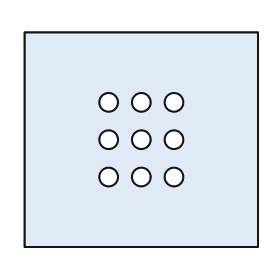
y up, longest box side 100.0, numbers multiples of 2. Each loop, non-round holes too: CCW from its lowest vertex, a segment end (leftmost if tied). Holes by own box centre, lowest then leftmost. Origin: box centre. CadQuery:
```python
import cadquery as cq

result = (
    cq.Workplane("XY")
    .moveTo(-50.0, -46.0)
    .lineTo(50.0, -46.0)
    .lineTo(50.0, 46.0)
    .lineTo(-50.0, 46.0)
    .close()
    .moveTo(-14.0, -16.0)
    .circle(4.0)
    .moveTo(0.0, -16.0)
    .circle(4.0)
    .moveTo(14.0, -16.0)
    .circle(4.0)
    .moveTo(-14.0, 0.0)
    .circle(4.0)
    .moveTo(0.0, 0.0)
    .circle(4.0)
    .moveTo(14.0, 0.0)
    .circle(4.0)
    .moveTo(-14.0, 16.0)
    .circle(4.0)
    .moveTo(0.0, 16.0)
    .circle(4.0)
    .moveTo(14.0, 16.0)
    .circle(4.0)
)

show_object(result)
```